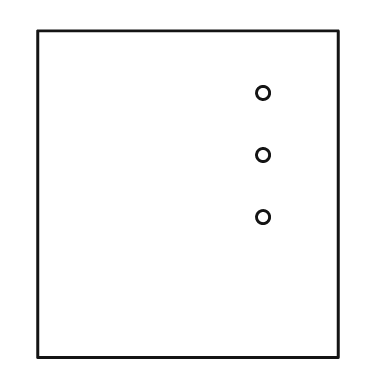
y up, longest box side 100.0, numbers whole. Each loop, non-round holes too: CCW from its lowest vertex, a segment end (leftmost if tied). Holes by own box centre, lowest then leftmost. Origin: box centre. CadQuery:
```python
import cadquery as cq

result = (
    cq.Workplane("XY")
    .moveTo(-46.0, -50.0)
    .lineTo(46.0, -50.0)
    .lineTo(46.0, 50.0)
    .lineTo(-46.0, 50.0)
    .close()
    .moveTo(23.0, -7.0)
    .circle(2.0)
    .moveTo(23.0, 12.0)
    .circle(2.0)
    .moveTo(23.0, 31.0)
    .circle(2.0)
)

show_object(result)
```